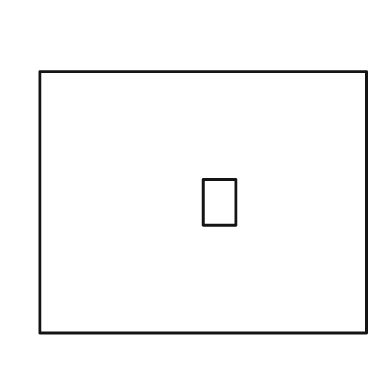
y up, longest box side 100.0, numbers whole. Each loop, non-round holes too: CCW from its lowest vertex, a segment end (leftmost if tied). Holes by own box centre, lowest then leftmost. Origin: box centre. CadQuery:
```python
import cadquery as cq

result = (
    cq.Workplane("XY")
    .moveTo(-50.0, -40.0)
    .lineTo(50.0, -40.0)
    .lineTo(50.0, 40.0)
    .lineTo(-50.0, 40.0)
    .close()
    .moveTo(0.0, -7.0)
    .lineTo(10.0, -7.0)
    .lineTo(10.0, 7.0)
    .lineTo(0.0, 7.0)
    .close()
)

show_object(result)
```